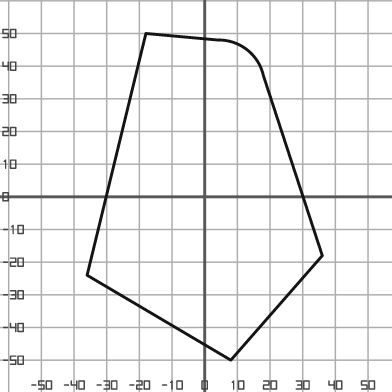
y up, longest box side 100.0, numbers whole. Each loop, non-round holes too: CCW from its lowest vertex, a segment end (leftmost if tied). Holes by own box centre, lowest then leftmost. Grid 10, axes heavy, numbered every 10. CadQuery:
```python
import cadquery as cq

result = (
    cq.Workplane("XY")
    .moveTo(8.0, -50.0)
    .lineTo(36.0, -18.0)
    .lineTo(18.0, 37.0)
    .threePointArc((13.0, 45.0), (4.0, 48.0))
    .lineTo(-18.0, 50.0)
    .lineTo(-36.0, -24.0)
    .close()
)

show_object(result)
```